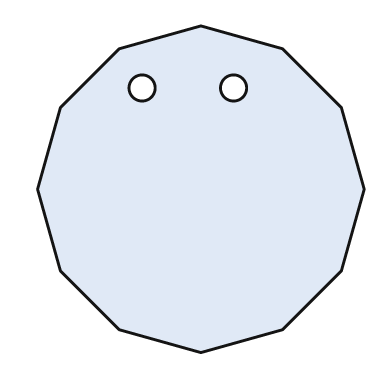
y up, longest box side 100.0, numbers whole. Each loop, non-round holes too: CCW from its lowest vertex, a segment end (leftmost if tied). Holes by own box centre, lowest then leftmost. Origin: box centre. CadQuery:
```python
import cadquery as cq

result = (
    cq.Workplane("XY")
    .moveTo(0.0, -50.0)
    .lineTo(25.0, -43.0)
    .lineTo(43.0, -25.0)
    .lineTo(50.0, 0.0)
    .lineTo(43.0, 25.0)
    .lineTo(25.0, 43.0)
    .lineTo(0.0, 50.0)
    .lineTo(-25.0, 43.0)
    .lineTo(-43.0, 25.0)
    .lineTo(-50.0, 0.0)
    .lineTo(-43.0, -25.0)
    .lineTo(-25.0, -43.0)
    .close()
    .moveTo(-18.0, 31.0)
    .circle(4.0)
    .moveTo(10.0, 31.0)
    .circle(4.0)
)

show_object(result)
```